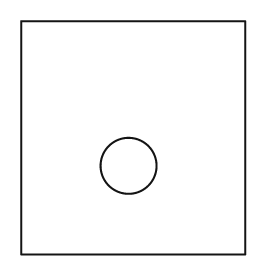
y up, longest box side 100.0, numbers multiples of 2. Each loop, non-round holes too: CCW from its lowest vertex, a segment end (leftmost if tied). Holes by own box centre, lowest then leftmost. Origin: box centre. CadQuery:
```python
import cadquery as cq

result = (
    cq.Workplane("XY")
    .moveTo(-48.0, -50.0)
    .lineTo(48.0, -50.0)
    .lineTo(48.0, 50.0)
    .lineTo(-48.0, 50.0)
    .close()
    .moveTo(-2.0, -12.0)
    .circle(12.0)
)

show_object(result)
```